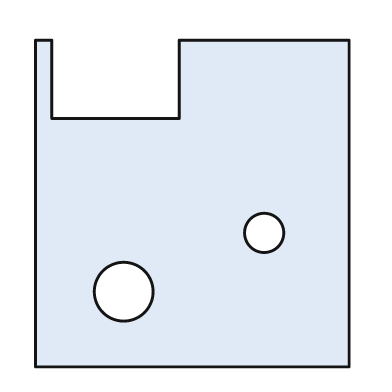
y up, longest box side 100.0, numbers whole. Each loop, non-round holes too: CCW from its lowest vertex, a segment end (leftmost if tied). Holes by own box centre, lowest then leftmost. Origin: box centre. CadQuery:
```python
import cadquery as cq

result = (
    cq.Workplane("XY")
    .moveTo(-48.0, -50.0)
    .lineTo(48.0, -50.0)
    .lineTo(48.0, 50.0)
    .lineTo(-4.0, 50.0)
    .lineTo(-4.0, 26.0)
    .lineTo(-43.0, 26.0)
    .lineTo(-43.0, 50.0)
    .lineTo(-48.0, 50.0)
    .close()
    .moveTo(-21.0, -27.0)
    .circle(9.0)
    .moveTo(22.0, -9.0)
    .circle(6.0)
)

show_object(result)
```